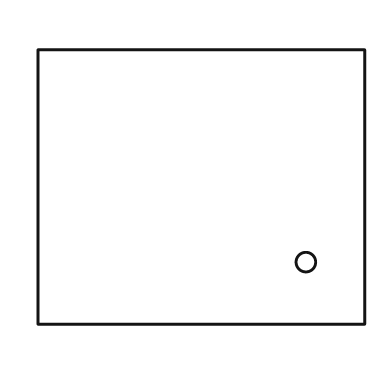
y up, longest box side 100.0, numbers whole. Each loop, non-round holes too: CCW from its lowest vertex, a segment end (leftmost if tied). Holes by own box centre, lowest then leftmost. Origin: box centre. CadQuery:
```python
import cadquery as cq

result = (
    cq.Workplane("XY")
    .moveTo(-50.0, -42.0)
    .lineTo(50.0, -42.0)
    .lineTo(50.0, 42.0)
    .lineTo(-50.0, 42.0)
    .close()
    .moveTo(32.0, -23.0)
    .circle(3.0)
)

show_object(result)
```